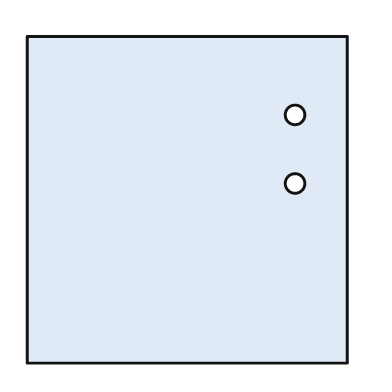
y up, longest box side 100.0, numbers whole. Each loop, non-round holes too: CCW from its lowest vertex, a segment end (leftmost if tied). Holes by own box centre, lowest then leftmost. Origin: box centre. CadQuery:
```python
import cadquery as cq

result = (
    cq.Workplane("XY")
    .moveTo(-49.0, -50.0)
    .lineTo(49.0, -50.0)
    .lineTo(49.0, 50.0)
    .lineTo(-49.0, 50.0)
    .close()
    .moveTo(33.0, 5.0)
    .circle(3.0)
    .moveTo(33.0, 26.0)
    .circle(3.0)
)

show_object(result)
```